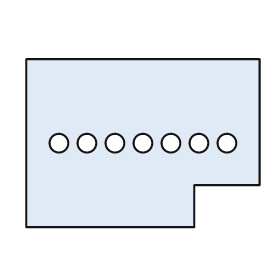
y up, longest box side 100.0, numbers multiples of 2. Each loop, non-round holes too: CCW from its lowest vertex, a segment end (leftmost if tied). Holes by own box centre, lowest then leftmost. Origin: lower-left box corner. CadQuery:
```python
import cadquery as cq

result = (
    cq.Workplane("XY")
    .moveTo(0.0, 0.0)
    .lineTo(72.0, 0.0)
    .lineTo(72.0, 18.0)
    .lineTo(100.0, 18.0)
    .lineTo(100.0, 72.0)
    .lineTo(0.0, 72.0)
    .close()
    .moveTo(14.0, 36.0)
    .circle(4.0)
    .moveTo(26.0, 36.0)
    .circle(4.0)
    .moveTo(38.0, 36.0)
    .circle(4.0)
    .moveTo(50.0, 36.0)
    .circle(4.0)
    .moveTo(62.0, 36.0)
    .circle(4.0)
    .moveTo(74.0, 36.0)
    .circle(4.0)
    .moveTo(86.0, 36.0)
    .circle(4.0)
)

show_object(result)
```